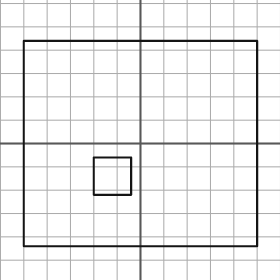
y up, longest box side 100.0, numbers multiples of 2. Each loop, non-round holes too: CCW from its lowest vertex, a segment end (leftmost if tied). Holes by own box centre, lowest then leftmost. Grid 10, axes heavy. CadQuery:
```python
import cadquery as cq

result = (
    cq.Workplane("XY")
    .moveTo(-50.0, -44.0)
    .lineTo(50.0, -44.0)
    .lineTo(50.0, 44.0)
    .lineTo(-50.0, 44.0)
    .close()
    .moveTo(-20.0, -22.0)
    .lineTo(-4.0, -22.0)
    .lineTo(-4.0, -6.0)
    .lineTo(-20.0, -6.0)
    .close()
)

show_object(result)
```